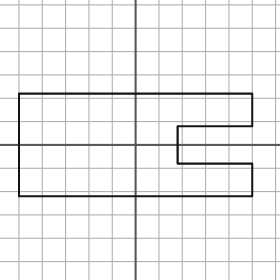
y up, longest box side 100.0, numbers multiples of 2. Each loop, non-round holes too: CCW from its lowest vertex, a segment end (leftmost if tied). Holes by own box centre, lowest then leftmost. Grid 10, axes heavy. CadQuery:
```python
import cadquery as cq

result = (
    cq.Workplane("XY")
    .moveTo(-50.0, -22.0)
    .lineTo(50.0, -22.0)
    .lineTo(50.0, -8.0)
    .lineTo(18.0, -8.0)
    .lineTo(18.0, 8.0)
    .lineTo(50.0, 8.0)
    .lineTo(50.0, 22.0)
    .lineTo(-50.0, 22.0)
    .close()
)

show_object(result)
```